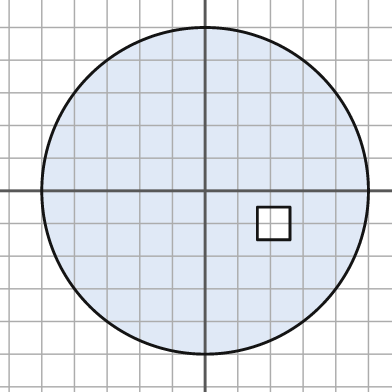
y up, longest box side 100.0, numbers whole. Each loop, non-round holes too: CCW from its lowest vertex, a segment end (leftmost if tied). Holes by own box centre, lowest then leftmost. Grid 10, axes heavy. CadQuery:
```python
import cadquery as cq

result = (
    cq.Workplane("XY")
    .moveTo(0.0, 0.0)
    .circle(50.0)
    .moveTo(16.0, -15.0)
    .lineTo(26.0, -15.0)
    .lineTo(26.0, -5.0)
    .lineTo(16.0, -5.0)
    .close()
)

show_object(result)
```